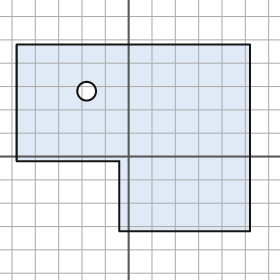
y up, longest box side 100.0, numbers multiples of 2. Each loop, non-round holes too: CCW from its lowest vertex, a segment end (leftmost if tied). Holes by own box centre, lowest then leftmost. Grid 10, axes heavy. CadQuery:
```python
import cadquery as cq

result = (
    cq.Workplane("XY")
    .moveTo(-4.0, -32.0)
    .lineTo(52.0, -32.0)
    .lineTo(52.0, 48.0)
    .lineTo(-48.0, 48.0)
    .lineTo(-48.0, -2.0)
    .lineTo(-4.0, -2.0)
    .close()
    .moveTo(-18.0, 28.0)
    .circle(4.0)
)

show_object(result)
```